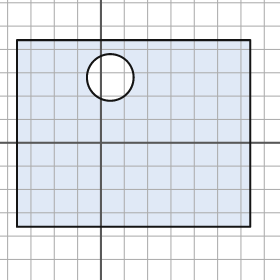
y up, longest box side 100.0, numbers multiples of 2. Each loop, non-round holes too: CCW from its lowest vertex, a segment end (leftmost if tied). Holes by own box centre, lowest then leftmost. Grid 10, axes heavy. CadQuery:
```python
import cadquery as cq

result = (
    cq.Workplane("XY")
    .moveTo(-36.0, -36.0)
    .lineTo(64.0, -36.0)
    .lineTo(64.0, 44.0)
    .lineTo(-36.0, 44.0)
    .close()
    .moveTo(4.0, 28.0)
    .circle(10.0)
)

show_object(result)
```